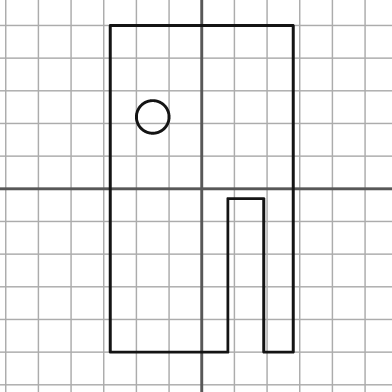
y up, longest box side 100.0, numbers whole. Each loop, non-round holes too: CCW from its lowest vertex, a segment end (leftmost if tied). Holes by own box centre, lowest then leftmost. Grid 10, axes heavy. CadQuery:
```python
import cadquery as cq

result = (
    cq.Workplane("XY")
    .moveTo(-28.0, -50.0)
    .lineTo(8.0, -50.0)
    .lineTo(8.0, -3.0)
    .lineTo(19.0, -3.0)
    .lineTo(19.0, -50.0)
    .lineTo(28.0, -50.0)
    .lineTo(28.0, 50.0)
    .lineTo(-28.0, 50.0)
    .close()
    .moveTo(-15.0, 22.0)
    .circle(5.0)
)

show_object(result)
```